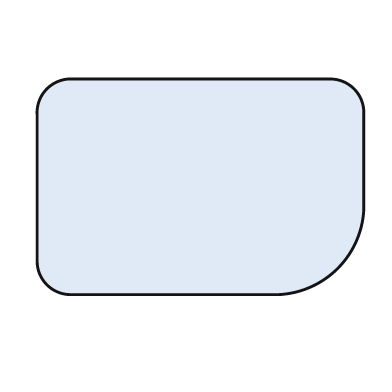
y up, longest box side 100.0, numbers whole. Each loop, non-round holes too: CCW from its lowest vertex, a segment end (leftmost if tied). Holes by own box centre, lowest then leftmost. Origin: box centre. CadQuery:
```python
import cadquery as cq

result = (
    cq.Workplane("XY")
    .moveTo(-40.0, -33.0)
    .lineTo(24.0, -33.0)
    .threePointArc((42.0, -25.0), (50.0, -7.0))
    .lineTo(50.0, 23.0)
    .threePointArc((47.0, 30.0), (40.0, 33.0))
    .lineTo(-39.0, 33.0)
    .threePointArc((-47.0, 30.0), (-50.0, 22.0))
    .lineTo(-50.0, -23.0)
    .threePointArc((-47.0, -30.0), (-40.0, -33.0))
    .close()
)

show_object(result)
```